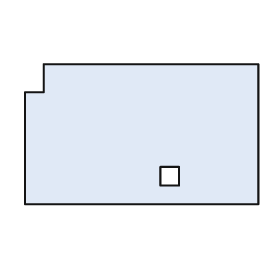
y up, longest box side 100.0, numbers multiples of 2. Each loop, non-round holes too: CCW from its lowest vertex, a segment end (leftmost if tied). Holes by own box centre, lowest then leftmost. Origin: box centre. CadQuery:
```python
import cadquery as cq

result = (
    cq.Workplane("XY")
    .moveTo(-50.0, -30.0)
    .lineTo(50.0, -30.0)
    .lineTo(50.0, 30.0)
    .lineTo(-42.0, 30.0)
    .lineTo(-42.0, 18.0)
    .lineTo(-50.0, 18.0)
    .close()
    .moveTo(8.0, -22.0)
    .lineTo(16.0, -22.0)
    .lineTo(16.0, -14.0)
    .lineTo(8.0, -14.0)
    .close()
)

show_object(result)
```